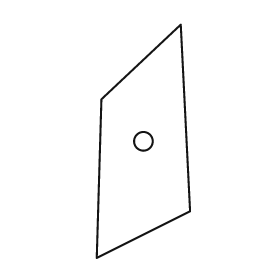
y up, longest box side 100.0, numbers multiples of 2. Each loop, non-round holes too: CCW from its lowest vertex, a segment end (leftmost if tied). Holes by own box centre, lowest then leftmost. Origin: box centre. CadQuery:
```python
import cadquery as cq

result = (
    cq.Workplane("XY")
    .moveTo(-20.0, -50.0)
    .lineTo(20.0, -30.0)
    .lineTo(16.0, 50.0)
    .lineTo(-18.0, 18.0)
    .close()
    .moveTo(0.0, 0.0)
    .circle(4.0)
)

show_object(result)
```